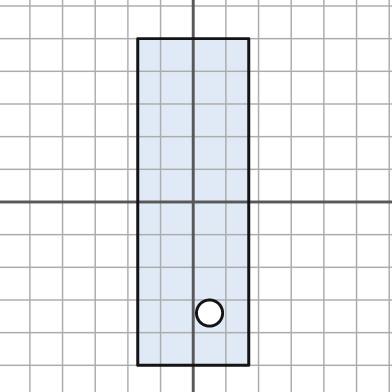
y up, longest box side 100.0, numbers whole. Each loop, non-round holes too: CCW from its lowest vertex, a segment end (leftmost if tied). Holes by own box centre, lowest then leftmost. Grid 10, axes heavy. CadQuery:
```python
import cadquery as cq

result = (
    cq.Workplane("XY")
    .moveTo(-17.0, -50.0)
    .lineTo(17.0, -50.0)
    .lineTo(17.0, 50.0)
    .lineTo(-17.0, 50.0)
    .close()
    .moveTo(5.0, -34.0)
    .circle(4.0)
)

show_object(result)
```